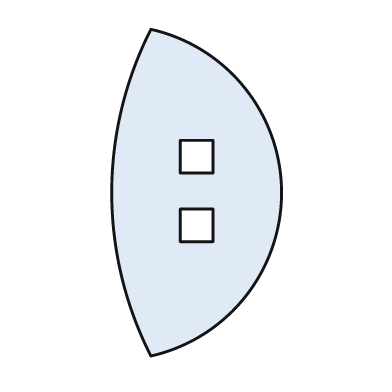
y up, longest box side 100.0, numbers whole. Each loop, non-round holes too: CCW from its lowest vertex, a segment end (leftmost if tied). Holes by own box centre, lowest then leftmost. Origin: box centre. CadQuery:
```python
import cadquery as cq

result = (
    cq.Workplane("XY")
    .moveTo(-14.0, -50.0)
    .threePointArc((26.0, 0.0), (-14.0, 50.0))
    .threePointArc((-26.0, 0.0), (-14.0, -50.0))
    .close()
    .moveTo(-5.0, -15.0)
    .lineTo(5.0, -15.0)
    .lineTo(5.0, -5.0)
    .lineTo(-5.0, -5.0)
    .close()
    .moveTo(-5.0, 6.0)
    .lineTo(5.0, 6.0)
    .lineTo(5.0, 16.0)
    .lineTo(-5.0, 16.0)
    .close()
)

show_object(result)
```